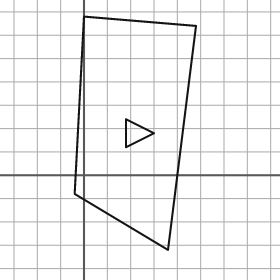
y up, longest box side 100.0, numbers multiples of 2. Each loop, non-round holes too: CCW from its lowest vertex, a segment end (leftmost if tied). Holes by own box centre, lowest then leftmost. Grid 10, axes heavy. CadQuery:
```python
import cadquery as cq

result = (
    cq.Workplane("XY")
    .moveTo(36.0, -32.0)
    .lineTo(48.0, 64.0)
    .lineTo(0.0, 68.0)
    .lineTo(-4.0, -8.0)
    .close()
    .moveTo(18.0, 12.0)
    .lineTo(30.0, 18.0)
    .lineTo(18.0, 24.0)
    .close()
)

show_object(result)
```